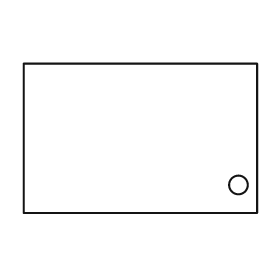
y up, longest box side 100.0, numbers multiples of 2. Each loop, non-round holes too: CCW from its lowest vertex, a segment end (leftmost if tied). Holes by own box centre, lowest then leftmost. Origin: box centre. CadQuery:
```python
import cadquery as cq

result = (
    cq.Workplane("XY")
    .moveTo(-50.0, -32.0)
    .lineTo(50.0, -32.0)
    .lineTo(50.0, 32.0)
    .lineTo(-50.0, 32.0)
    .close()
    .moveTo(42.0, -20.0)
    .circle(4.0)
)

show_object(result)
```